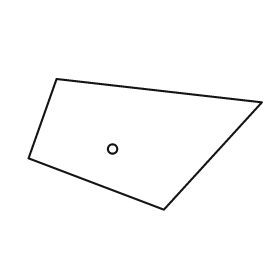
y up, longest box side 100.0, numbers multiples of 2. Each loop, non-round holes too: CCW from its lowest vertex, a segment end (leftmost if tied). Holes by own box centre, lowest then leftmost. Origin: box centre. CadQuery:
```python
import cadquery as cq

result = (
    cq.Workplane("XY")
    .moveTo(8.0, -28.0)
    .lineTo(50.0, 18.0)
    .lineTo(-38.0, 28.0)
    .lineTo(-50.0, -6.0)
    .close()
    .moveTo(-14.0, -2.0)
    .circle(2.0)
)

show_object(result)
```